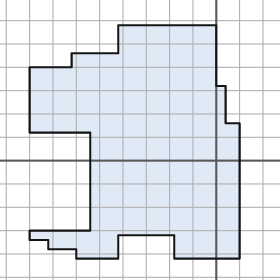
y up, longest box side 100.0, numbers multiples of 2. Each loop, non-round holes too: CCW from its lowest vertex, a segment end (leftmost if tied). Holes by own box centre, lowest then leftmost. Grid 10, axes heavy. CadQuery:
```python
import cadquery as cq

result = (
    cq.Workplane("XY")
    .moveTo(-60.0, -42.0)
    .lineTo(-42.0, -42.0)
    .lineTo(-42.0, -32.0)
    .lineTo(-18.0, -32.0)
    .lineTo(-18.0, -42.0)
    .lineTo(10.0, -42.0)
    .lineTo(10.0, 16.0)
    .lineTo(4.0, 16.0)
    .lineTo(4.0, 32.0)
    .lineTo(0.0, 32.0)
    .lineTo(0.0, 58.0)
    .lineTo(-42.0, 58.0)
    .lineTo(-42.0, 46.0)
    .lineTo(-62.0, 46.0)
    .lineTo(-62.0, 40.0)
    .lineTo(-80.0, 40.0)
    .lineTo(-80.0, 12.0)
    .lineTo(-54.0, 12.0)
    .lineTo(-54.0, -30.0)
    .lineTo(-80.0, -30.0)
    .lineTo(-80.0, -34.0)
    .lineTo(-72.0, -34.0)
    .lineTo(-72.0, -38.0)
    .lineTo(-60.0, -38.0)
    .close()
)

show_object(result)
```